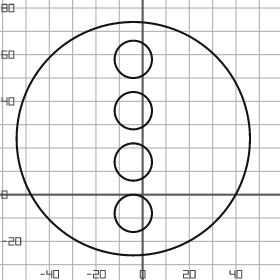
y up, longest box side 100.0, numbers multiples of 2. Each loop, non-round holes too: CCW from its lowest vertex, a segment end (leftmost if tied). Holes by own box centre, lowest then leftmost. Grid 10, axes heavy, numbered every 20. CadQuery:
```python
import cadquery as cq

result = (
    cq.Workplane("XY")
    .moveTo(-4.0, 24.0)
    .circle(50.0)
    .moveTo(-4.0, -8.0)
    .circle(8.0)
    .moveTo(-4.0, 14.0)
    .circle(8.0)
    .moveTo(-4.0, 36.0)
    .circle(8.0)
    .moveTo(-4.0, 58.0)
    .circle(8.0)
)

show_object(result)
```